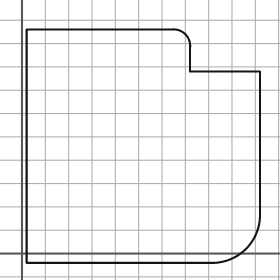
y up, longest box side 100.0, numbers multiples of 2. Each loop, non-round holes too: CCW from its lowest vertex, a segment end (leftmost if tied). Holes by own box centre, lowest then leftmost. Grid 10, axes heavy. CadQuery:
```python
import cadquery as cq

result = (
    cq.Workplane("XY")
    .moveTo(2.0, -4.0)
    .lineTo(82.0, -4.0)
    .threePointArc((96.0, 2.0), (102.0, 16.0))
    .lineTo(102.0, 78.0)
    .lineTo(72.0, 78.0)
    .lineTo(72.0, 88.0)
    .threePointArc((70.0, 94.0), (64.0, 96.0))
    .lineTo(2.0, 96.0)
    .close()
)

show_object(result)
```